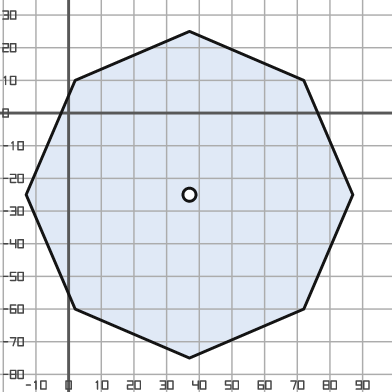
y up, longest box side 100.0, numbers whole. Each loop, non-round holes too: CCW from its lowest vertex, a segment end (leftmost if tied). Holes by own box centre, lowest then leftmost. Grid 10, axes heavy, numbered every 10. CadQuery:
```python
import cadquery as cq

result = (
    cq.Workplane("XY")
    .moveTo(37.0, -75.0)
    .lineTo(72.0, -60.0)
    .lineTo(87.0, -25.0)
    .lineTo(72.0, 10.0)
    .lineTo(37.0, 25.0)
    .lineTo(2.0, 10.0)
    .lineTo(-13.0, -25.0)
    .lineTo(2.0, -60.0)
    .close()
    .moveTo(37.0, -25.0)
    .circle(2.0)
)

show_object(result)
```